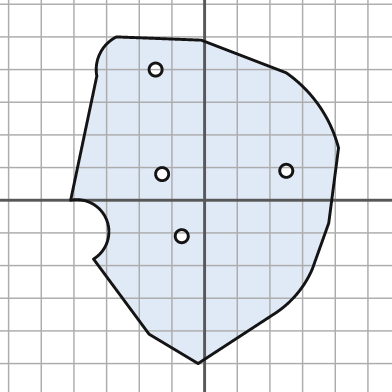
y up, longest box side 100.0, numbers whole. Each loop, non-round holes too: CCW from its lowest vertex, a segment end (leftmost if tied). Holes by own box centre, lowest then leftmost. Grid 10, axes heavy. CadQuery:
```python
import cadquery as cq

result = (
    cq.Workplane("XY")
    .moveTo(-2.0, -50.0)
    .lineTo(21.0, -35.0)
    .threePointArc((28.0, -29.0), (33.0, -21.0))
    .lineTo(38.0, -7.0)
    .lineTo(41.0, 16.0)
    .threePointArc((35.0, 29.0), (25.0, 39.0))
    .lineTo(-1.0, 49.0)
    .lineTo(-27.0, 50.0)
    .threePointArc((-32.0, 45.0), (-33.0, 38.0))
    .lineTo(-41.0, 0.0)
    .threePointArc((-30.0, -6.0), (-34.0, -18.0))
    .lineTo(-17.0, -41.0)
    .close()
    .moveTo(-7.0, -11.0)
    .circle(2.0)
    .moveTo(-13.0, 8.0)
    .circle(2.0)
    .moveTo(25.0, 9.0)
    .circle(2.0)
    .moveTo(-15.0, 40.0)
    .circle(2.0)
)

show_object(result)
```